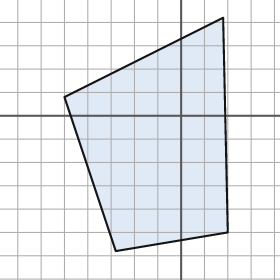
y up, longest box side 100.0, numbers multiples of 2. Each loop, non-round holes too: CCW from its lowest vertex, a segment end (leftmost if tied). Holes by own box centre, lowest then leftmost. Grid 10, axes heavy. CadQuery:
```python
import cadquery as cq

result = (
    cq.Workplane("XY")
    .moveTo(-28.0, -58.0)
    .lineTo(20.0, -50.0)
    .lineTo(18.0, 42.0)
    .lineTo(-50.0, 8.0)
    .close()
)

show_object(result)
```